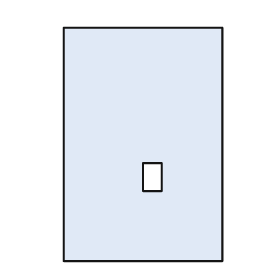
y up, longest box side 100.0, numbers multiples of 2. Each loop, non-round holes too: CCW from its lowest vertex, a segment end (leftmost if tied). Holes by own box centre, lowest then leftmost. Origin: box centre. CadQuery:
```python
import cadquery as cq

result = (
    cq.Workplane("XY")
    .moveTo(-34.0, -50.0)
    .lineTo(34.0, -50.0)
    .lineTo(34.0, 50.0)
    .lineTo(-34.0, 50.0)
    .close()
    .moveTo(0.0, -20.0)
    .lineTo(8.0, -20.0)
    .lineTo(8.0, -8.0)
    .lineTo(0.0, -8.0)
    .close()
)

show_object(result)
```